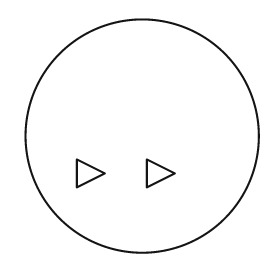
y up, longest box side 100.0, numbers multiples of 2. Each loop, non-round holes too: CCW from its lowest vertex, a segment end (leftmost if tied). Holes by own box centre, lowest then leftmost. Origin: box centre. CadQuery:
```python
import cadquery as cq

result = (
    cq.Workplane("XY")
    .moveTo(0.0, 0.0)
    .circle(50.0)
    .moveTo(-28.0, -22.0)
    .lineTo(-16.0, -16.0)
    .lineTo(-28.0, -10.0)
    .close()
    .moveTo(2.0, -22.0)
    .lineTo(14.0, -16.0)
    .lineTo(2.0, -10.0)
    .close()
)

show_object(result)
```